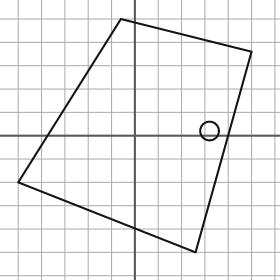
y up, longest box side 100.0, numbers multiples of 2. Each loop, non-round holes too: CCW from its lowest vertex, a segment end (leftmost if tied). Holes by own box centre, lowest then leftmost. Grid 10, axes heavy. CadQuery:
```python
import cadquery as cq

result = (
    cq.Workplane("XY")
    .moveTo(26.0, -50.0)
    .lineTo(50.0, 36.0)
    .lineTo(-6.0, 50.0)
    .lineTo(-50.0, -20.0)
    .close()
    .moveTo(32.0, 2.0)
    .circle(4.0)
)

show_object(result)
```